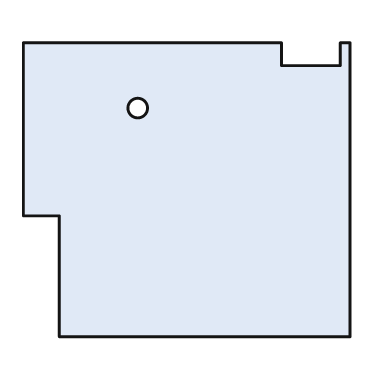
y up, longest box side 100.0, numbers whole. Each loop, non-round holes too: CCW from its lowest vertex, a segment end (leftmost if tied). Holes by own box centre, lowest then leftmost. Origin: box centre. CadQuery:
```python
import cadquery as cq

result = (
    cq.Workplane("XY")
    .moveTo(-39.0, -45.0)
    .lineTo(50.0, -45.0)
    .lineTo(50.0, 45.0)
    .lineTo(47.0, 45.0)
    .lineTo(47.0, 38.0)
    .lineTo(29.0, 38.0)
    .lineTo(29.0, 45.0)
    .lineTo(-50.0, 45.0)
    .lineTo(-50.0, -8.0)
    .lineTo(-39.0, -8.0)
    .close()
    .moveTo(-15.0, 25.0)
    .circle(3.0)
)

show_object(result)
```